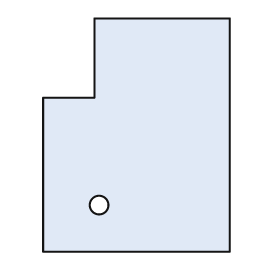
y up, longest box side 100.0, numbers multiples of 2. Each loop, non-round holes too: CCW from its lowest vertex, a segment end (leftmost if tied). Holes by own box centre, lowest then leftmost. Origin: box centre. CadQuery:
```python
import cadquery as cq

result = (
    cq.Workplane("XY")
    .moveTo(-40.0, -50.0)
    .lineTo(40.0, -50.0)
    .lineTo(40.0, 50.0)
    .lineTo(-18.0, 50.0)
    .lineTo(-18.0, 16.0)
    .lineTo(-40.0, 16.0)
    .close()
    .moveTo(-16.0, -30.0)
    .circle(4.0)
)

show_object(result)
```